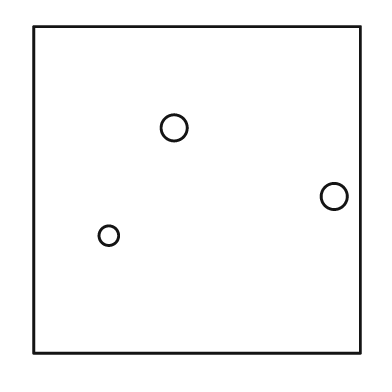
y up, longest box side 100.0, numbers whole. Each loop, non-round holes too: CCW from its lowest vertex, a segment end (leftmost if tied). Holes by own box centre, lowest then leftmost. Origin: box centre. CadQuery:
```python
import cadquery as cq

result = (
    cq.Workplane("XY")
    .moveTo(-50.0, -50.0)
    .lineTo(50.0, -50.0)
    .lineTo(50.0, 50.0)
    .lineTo(-50.0, 50.0)
    .close()
    .moveTo(-27.0, -14.0)
    .circle(3.0)
    .moveTo(42.0, -2.0)
    .circle(4.0)
    .moveTo(-7.0, 19.0)
    .circle(4.0)
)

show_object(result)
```